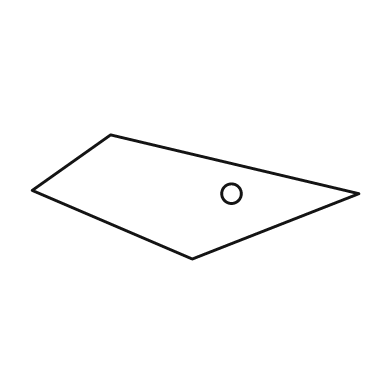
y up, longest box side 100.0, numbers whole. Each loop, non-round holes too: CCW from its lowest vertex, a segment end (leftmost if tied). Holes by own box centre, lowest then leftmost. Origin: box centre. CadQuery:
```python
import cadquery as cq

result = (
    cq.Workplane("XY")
    .moveTo(-1.0, -19.0)
    .lineTo(50.0, 1.0)
    .lineTo(-26.0, 19.0)
    .lineTo(-50.0, 2.0)
    .close()
    .moveTo(11.0, 1.0)
    .circle(3.0)
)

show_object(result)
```